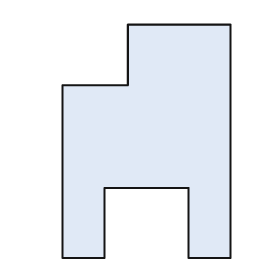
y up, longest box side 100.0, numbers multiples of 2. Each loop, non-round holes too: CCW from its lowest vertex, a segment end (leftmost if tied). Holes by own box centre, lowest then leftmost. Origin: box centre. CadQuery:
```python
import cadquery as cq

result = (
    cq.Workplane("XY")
    .moveTo(-36.0, -50.0)
    .lineTo(-18.0, -50.0)
    .lineTo(-18.0, -20.0)
    .lineTo(18.0, -20.0)
    .lineTo(18.0, -50.0)
    .lineTo(36.0, -50.0)
    .lineTo(36.0, 50.0)
    .lineTo(-8.0, 50.0)
    .lineTo(-8.0, 24.0)
    .lineTo(-36.0, 24.0)
    .close()
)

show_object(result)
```